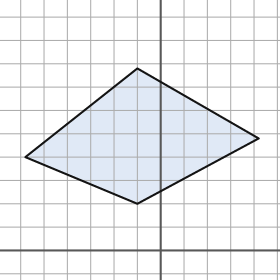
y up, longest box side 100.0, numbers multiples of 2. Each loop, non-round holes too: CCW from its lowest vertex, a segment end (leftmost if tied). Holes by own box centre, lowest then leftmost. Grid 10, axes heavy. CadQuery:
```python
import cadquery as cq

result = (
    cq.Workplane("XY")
    .moveTo(-10.0, 20.0)
    .lineTo(42.0, 48.0)
    .lineTo(-10.0, 78.0)
    .lineTo(-58.0, 40.0)
    .close()
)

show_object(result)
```